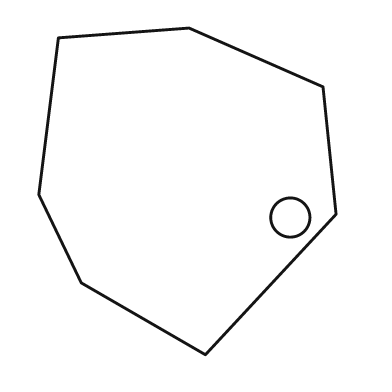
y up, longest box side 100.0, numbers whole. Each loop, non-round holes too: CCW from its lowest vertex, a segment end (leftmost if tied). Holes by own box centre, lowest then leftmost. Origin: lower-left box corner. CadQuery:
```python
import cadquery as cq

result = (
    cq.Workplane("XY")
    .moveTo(51.0, 0.0)
    .lineTo(91.0, 43.0)
    .lineTo(87.0, 82.0)
    .lineTo(46.0, 100.0)
    .lineTo(6.0, 97.0)
    .lineTo(0.0, 49.0)
    .lineTo(13.0, 22.0)
    .close()
    .moveTo(77.0, 42.0)
    .circle(6.0)
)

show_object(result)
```